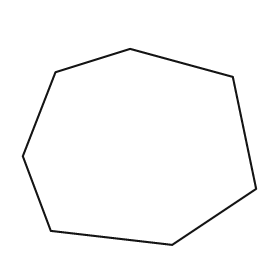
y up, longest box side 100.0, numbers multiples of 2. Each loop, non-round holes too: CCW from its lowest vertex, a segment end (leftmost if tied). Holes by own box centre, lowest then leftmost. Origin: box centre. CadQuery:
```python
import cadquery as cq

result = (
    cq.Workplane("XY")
    .moveTo(14.0, -42.0)
    .lineTo(50.0, -18.0)
    .lineTo(40.0, 30.0)
    .lineTo(-4.0, 42.0)
    .lineTo(-36.0, 32.0)
    .lineTo(-50.0, -4.0)
    .lineTo(-38.0, -36.0)
    .close()
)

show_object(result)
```